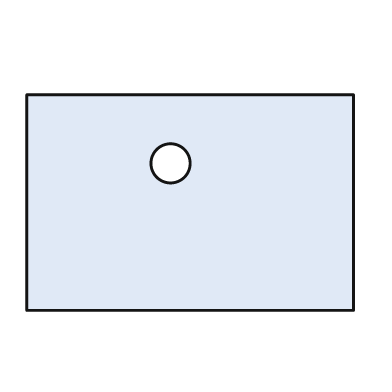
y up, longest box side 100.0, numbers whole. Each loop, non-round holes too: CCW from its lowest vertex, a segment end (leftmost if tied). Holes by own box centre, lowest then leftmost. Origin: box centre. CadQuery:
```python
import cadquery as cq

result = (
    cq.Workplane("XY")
    .moveTo(-50.0, -33.0)
    .lineTo(50.0, -33.0)
    .lineTo(50.0, 33.0)
    .lineTo(-50.0, 33.0)
    .close()
    .moveTo(-6.0, 12.0)
    .circle(6.0)
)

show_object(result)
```